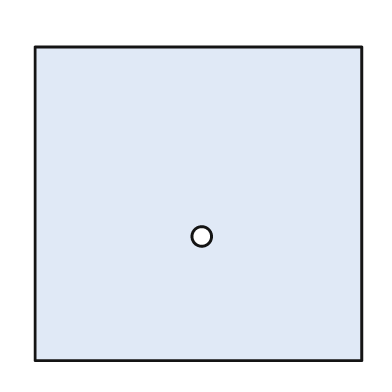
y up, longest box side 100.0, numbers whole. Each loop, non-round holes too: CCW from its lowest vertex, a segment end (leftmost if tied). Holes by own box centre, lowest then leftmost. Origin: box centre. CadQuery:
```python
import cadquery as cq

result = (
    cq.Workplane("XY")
    .moveTo(-50.0, -48.0)
    .lineTo(50.0, -48.0)
    .lineTo(50.0, 48.0)
    .lineTo(-50.0, 48.0)
    .close()
    .moveTo(1.0, -10.0)
    .circle(3.0)
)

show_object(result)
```